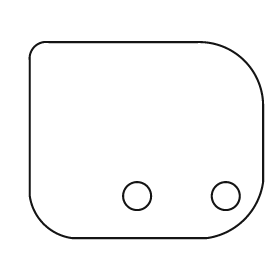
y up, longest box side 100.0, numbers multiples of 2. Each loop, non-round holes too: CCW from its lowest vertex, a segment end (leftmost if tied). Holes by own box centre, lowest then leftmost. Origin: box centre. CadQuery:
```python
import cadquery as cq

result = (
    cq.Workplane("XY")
    .moveTo(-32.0, -42.0)
    .lineTo(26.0, -42.0)
    .threePointArc((42.0, -34.0), (50.0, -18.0))
    .lineTo(50.0, 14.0)
    .threePointArc((42.0, 34.0), (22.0, 42.0))
    .lineTo(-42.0, 42.0)
    .threePointArc((-48.0, 40.0), (-50.0, 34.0))
    .lineTo(-50.0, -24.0)
    .threePointArc((-44.0, -36.0), (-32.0, -42.0))
    .close()
    .moveTo(-4.0, -24.0)
    .circle(6.0)
    .moveTo(34.0, -24.0)
    .circle(6.0)
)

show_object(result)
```